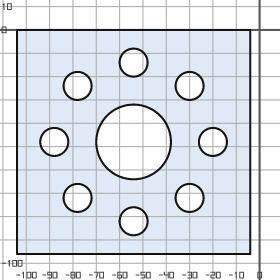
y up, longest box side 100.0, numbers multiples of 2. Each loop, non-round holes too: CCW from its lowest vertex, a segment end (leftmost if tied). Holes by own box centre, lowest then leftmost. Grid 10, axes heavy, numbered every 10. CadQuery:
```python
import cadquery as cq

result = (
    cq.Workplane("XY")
    .moveTo(-104.0, -96.0)
    .lineTo(-4.0, -96.0)
    .lineTo(-4.0, 0.0)
    .lineTo(-104.0, 0.0)
    .close()
    .moveTo(-54.0, -82.0)
    .circle(6.0)
    .moveTo(-78.0, -72.0)
    .circle(6.0)
    .moveTo(-30.0, -72.0)
    .circle(6.0)
    .moveTo(-88.0, -48.0)
    .circle(6.0)
    .moveTo(-54.0, -48.0)
    .circle(16.0)
    .moveTo(-20.0, -48.0)
    .circle(6.0)
    .moveTo(-78.0, -24.0)
    .circle(6.0)
    .moveTo(-30.0, -24.0)
    .circle(6.0)
    .moveTo(-54.0, -14.0)
    .circle(6.0)
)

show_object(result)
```